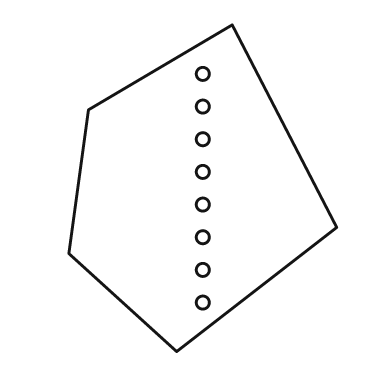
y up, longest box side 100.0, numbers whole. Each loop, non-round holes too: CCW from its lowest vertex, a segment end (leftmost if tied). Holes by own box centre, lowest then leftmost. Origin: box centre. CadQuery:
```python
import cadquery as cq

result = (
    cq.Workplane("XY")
    .moveTo(-8.0, -50.0)
    .lineTo(41.0, -12.0)
    .lineTo(9.0, 50.0)
    .lineTo(-35.0, 24.0)
    .lineTo(-41.0, -20.0)
    .close()
    .moveTo(0.0, -35.0)
    .circle(2.0)
    .moveTo(0.0, -25.0)
    .circle(2.0)
    .moveTo(0.0, -15.0)
    .circle(2.0)
    .moveTo(0.0, -5.0)
    .circle(2.0)
    .moveTo(0.0, 5.0)
    .circle(2.0)
    .moveTo(0.0, 15.0)
    .circle(2.0)
    .moveTo(0.0, 25.0)
    .circle(2.0)
    .moveTo(0.0, 35.0)
    .circle(2.0)
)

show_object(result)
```